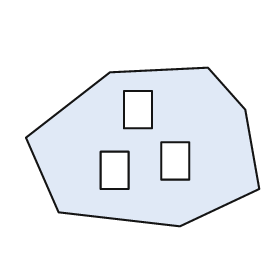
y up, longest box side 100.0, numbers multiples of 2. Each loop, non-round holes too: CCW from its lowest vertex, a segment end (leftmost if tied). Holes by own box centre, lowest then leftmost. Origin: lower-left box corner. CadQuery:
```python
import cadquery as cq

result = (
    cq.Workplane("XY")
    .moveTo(66.0, 0.0)
    .lineTo(100.0, 16.0)
    .lineTo(94.0, 50.0)
    .lineTo(78.0, 68.0)
    .lineTo(36.0, 66.0)
    .lineTo(0.0, 38.0)
    .lineTo(14.0, 6.0)
    .close()
    .moveTo(32.0, 16.0)
    .lineTo(44.0, 16.0)
    .lineTo(44.0, 32.0)
    .lineTo(32.0, 32.0)
    .close()
    .moveTo(58.0, 20.0)
    .lineTo(70.0, 20.0)
    .lineTo(70.0, 36.0)
    .lineTo(58.0, 36.0)
    .close()
    .moveTo(42.0, 42.0)
    .lineTo(54.0, 42.0)
    .lineTo(54.0, 58.0)
    .lineTo(42.0, 58.0)
    .close()
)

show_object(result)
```